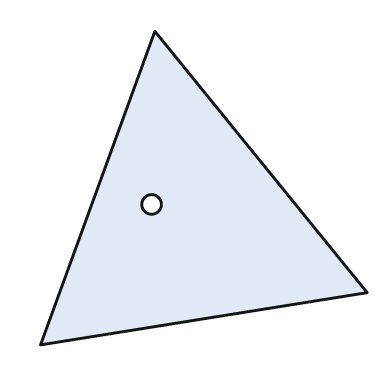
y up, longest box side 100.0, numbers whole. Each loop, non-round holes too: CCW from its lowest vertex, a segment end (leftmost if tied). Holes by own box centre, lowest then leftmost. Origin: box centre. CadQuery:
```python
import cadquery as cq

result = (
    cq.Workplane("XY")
    .moveTo(-50.0, -48.0)
    .lineTo(50.0, -32.0)
    .lineTo(-15.0, 48.0)
    .close()
    .moveTo(-16.0, -5.0)
    .circle(3.0)
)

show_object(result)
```